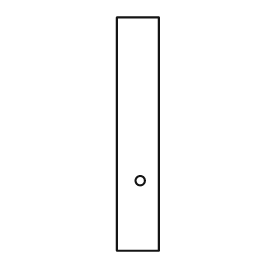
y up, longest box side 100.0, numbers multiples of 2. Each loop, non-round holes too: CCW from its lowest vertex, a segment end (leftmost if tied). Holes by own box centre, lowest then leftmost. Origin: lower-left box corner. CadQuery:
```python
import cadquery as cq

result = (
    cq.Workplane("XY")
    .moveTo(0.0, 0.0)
    .lineTo(18.0, 0.0)
    .lineTo(18.0, 100.0)
    .lineTo(0.0, 100.0)
    .close()
    .moveTo(10.0, 30.0)
    .circle(2.0)
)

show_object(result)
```